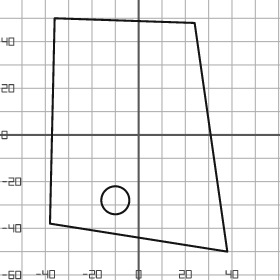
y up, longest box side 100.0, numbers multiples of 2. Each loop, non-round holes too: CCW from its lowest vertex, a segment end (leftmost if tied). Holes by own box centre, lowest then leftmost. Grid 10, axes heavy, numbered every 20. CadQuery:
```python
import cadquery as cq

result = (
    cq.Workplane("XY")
    .moveTo(38.0, -50.0)
    .lineTo(24.0, 48.0)
    .lineTo(-36.0, 50.0)
    .lineTo(-38.0, -38.0)
    .close()
    .moveTo(-10.0, -28.0)
    .circle(6.0)
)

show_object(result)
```